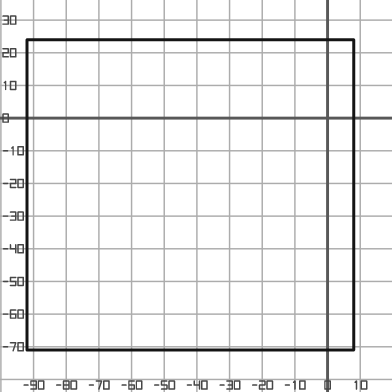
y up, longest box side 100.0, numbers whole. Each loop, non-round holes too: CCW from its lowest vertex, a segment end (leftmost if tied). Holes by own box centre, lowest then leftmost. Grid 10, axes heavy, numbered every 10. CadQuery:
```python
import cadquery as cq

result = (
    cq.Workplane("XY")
    .moveTo(-92.0, -71.0)
    .lineTo(8.0, -71.0)
    .lineTo(8.0, 24.0)
    .lineTo(-92.0, 24.0)
    .close()
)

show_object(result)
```